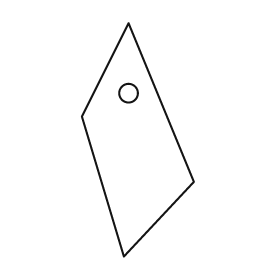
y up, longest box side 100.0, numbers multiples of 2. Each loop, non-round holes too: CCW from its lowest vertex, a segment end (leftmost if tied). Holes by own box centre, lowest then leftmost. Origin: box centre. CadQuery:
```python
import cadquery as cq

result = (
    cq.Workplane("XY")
    .moveTo(-6.0, -50.0)
    .lineTo(24.0, -18.0)
    .lineTo(-4.0, 50.0)
    .lineTo(-24.0, 10.0)
    .close()
    .moveTo(-4.0, 20.0)
    .circle(4.0)
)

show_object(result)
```